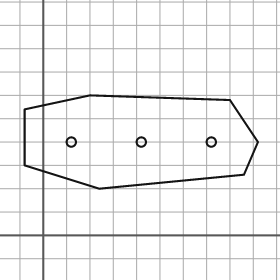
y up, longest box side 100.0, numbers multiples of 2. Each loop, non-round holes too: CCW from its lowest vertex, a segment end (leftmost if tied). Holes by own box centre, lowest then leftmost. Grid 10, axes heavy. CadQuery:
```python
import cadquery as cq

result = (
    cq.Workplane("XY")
    .moveTo(24.0, 20.0)
    .lineTo(86.0, 26.0)
    .lineTo(92.0, 40.0)
    .lineTo(80.0, 58.0)
    .lineTo(20.0, 60.0)
    .lineTo(-8.0, 54.0)
    .lineTo(-8.0, 30.0)
    .close()
    .moveTo(12.0, 40.0)
    .circle(2.0)
    .moveTo(42.0, 40.0)
    .circle(2.0)
    .moveTo(72.0, 40.0)
    .circle(2.0)
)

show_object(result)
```